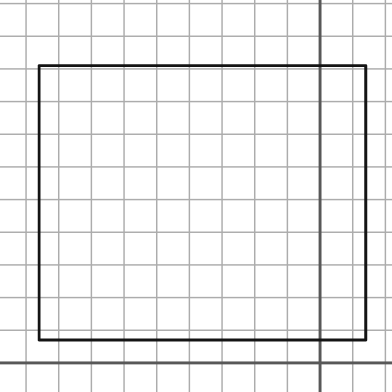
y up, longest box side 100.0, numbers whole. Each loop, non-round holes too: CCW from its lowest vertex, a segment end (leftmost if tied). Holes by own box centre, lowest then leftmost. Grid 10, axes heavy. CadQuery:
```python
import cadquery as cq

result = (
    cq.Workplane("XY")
    .moveTo(-86.0, 7.0)
    .lineTo(14.0, 7.0)
    .lineTo(14.0, 91.0)
    .lineTo(-86.0, 91.0)
    .close()
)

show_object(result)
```